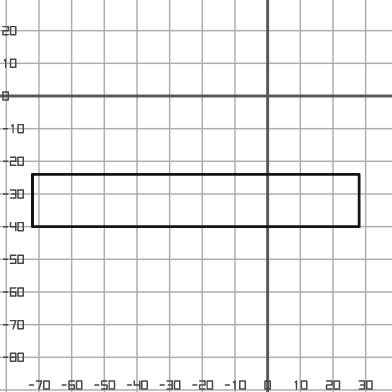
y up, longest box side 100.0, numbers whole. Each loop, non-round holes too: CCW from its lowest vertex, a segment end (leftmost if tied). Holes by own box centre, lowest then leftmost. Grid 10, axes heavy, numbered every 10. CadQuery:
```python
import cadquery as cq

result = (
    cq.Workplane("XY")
    .moveTo(-72.0, -40.0)
    .lineTo(28.0, -40.0)
    .lineTo(28.0, -24.0)
    .lineTo(-72.0, -24.0)
    .close()
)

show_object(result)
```